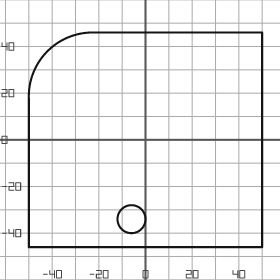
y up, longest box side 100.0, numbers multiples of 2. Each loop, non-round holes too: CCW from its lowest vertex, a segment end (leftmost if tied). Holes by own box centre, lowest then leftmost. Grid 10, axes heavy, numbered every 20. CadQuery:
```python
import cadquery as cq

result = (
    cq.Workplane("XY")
    .moveTo(-50.0, -46.0)
    .lineTo(50.0, -46.0)
    .lineTo(50.0, 46.0)
    .lineTo(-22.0, 46.0)
    .threePointArc((-42.0, 38.0), (-50.0, 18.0))
    .close()
    .moveTo(-6.0, -34.0)
    .circle(6.0)
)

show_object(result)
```